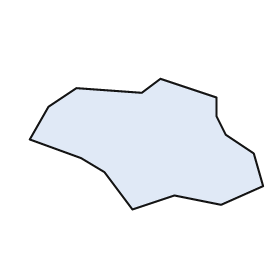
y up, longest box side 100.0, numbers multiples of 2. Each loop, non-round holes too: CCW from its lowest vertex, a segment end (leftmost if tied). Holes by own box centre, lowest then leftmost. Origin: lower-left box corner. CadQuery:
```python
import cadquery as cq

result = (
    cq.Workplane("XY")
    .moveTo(44.0, 0.0)
    .lineTo(62.0, 6.0)
    .lineTo(82.0, 2.0)
    .lineTo(100.0, 10.0)
    .lineTo(96.0, 24.0)
    .lineTo(84.0, 32.0)
    .lineTo(80.0, 40.0)
    .lineTo(80.0, 48.0)
    .lineTo(56.0, 56.0)
    .lineTo(48.0, 50.0)
    .lineTo(20.0, 52.0)
    .lineTo(8.0, 44.0)
    .lineTo(0.0, 30.0)
    .lineTo(22.0, 22.0)
    .lineTo(32.0, 16.0)
    .close()
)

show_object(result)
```